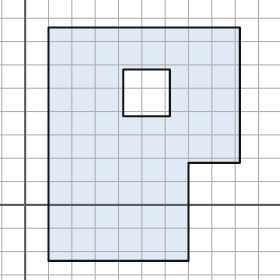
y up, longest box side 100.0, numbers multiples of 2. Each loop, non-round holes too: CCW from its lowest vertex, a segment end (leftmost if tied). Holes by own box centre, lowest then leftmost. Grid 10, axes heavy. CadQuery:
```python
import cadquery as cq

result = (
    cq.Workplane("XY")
    .moveTo(10.0, -24.0)
    .lineTo(70.0, -24.0)
    .lineTo(70.0, 18.0)
    .lineTo(92.0, 18.0)
    .lineTo(92.0, 76.0)
    .lineTo(10.0, 76.0)
    .close()
    .moveTo(42.0, 38.0)
    .lineTo(62.0, 38.0)
    .lineTo(62.0, 58.0)
    .lineTo(42.0, 58.0)
    .close()
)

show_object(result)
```